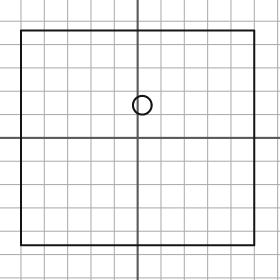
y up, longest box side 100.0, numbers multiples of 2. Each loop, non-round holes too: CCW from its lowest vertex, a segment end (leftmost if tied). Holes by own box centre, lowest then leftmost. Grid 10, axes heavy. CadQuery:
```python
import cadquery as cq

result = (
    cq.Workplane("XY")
    .moveTo(-50.0, -46.0)
    .lineTo(50.0, -46.0)
    .lineTo(50.0, 46.0)
    .lineTo(-50.0, 46.0)
    .close()
    .moveTo(2.0, 14.0)
    .circle(4.0)
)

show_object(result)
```